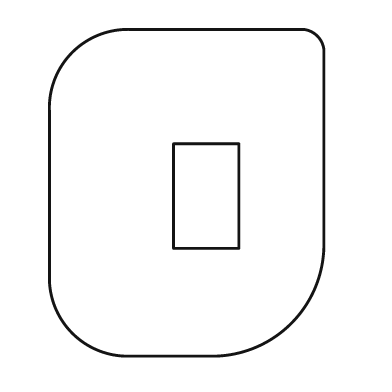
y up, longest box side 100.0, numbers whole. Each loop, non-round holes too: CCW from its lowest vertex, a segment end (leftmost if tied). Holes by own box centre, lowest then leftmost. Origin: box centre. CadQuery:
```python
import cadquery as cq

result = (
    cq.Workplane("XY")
    .moveTo(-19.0, -50.0)
    .lineTo(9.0, -50.0)
    .threePointArc((32.0, -40.0), (42.0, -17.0))
    .lineTo(42.0, 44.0)
    .threePointArc((40.0, 48.0), (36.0, 50.0))
    .lineTo(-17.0, 50.0)
    .threePointArc((-35.0, 43.0), (-42.0, 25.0))
    .lineTo(-42.0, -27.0)
    .threePointArc((-35.0, -43.0), (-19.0, -50.0))
    .close()
    .moveTo(-4.0, -17.0)
    .lineTo(16.0, -17.0)
    .lineTo(16.0, 15.0)
    .lineTo(-4.0, 15.0)
    .close()
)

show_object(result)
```